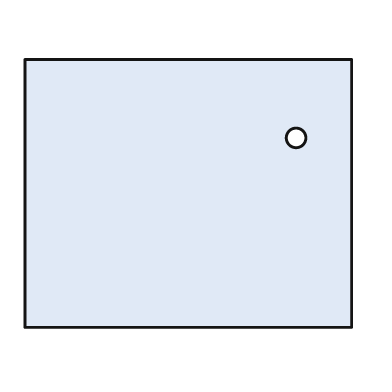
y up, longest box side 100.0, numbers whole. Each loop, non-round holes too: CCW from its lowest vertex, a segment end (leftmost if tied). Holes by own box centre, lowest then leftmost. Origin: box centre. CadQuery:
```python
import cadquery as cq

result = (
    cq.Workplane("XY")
    .moveTo(-50.0, -41.0)
    .lineTo(50.0, -41.0)
    .lineTo(50.0, 41.0)
    .lineTo(-50.0, 41.0)
    .close()
    .moveTo(33.0, 17.0)
    .circle(3.0)
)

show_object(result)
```